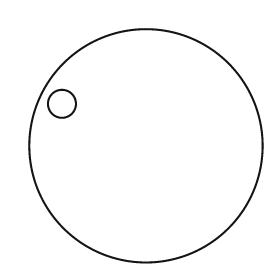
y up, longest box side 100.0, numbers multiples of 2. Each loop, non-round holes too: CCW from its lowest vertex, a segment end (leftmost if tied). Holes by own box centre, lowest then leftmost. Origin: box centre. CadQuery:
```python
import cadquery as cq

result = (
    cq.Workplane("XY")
    .moveTo(0.0, 0.0)
    .circle(50.0)
    .moveTo(-36.0, 18.0)
    .circle(6.0)
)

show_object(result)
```